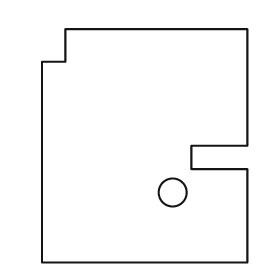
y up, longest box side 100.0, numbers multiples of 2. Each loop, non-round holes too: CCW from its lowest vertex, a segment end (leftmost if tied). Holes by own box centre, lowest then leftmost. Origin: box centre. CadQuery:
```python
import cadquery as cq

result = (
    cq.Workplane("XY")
    .moveTo(-44.0, -50.0)
    .lineTo(44.0, -50.0)
    .lineTo(44.0, -10.0)
    .lineTo(20.0, -10.0)
    .lineTo(20.0, 0.0)
    .lineTo(44.0, 0.0)
    .lineTo(44.0, 50.0)
    .lineTo(-34.0, 50.0)
    .lineTo(-34.0, 36.0)
    .lineTo(-44.0, 36.0)
    .close()
    .moveTo(12.0, -20.0)
    .circle(6.0)
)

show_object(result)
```